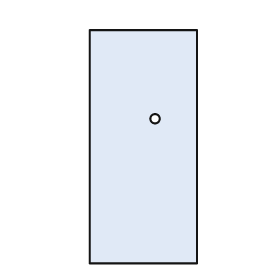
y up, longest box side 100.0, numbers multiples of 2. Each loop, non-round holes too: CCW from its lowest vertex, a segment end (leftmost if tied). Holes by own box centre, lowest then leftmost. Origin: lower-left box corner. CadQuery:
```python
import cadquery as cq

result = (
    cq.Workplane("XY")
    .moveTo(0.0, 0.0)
    .lineTo(46.0, 0.0)
    .lineTo(46.0, 100.0)
    .lineTo(0.0, 100.0)
    .close()
    .moveTo(28.0, 62.0)
    .circle(2.0)
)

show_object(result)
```